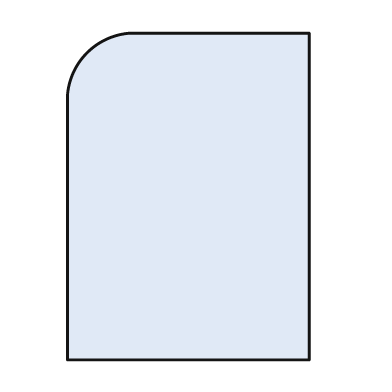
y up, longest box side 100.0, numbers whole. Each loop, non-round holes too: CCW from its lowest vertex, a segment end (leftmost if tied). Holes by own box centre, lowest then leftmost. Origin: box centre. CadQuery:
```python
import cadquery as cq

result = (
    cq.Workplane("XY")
    .moveTo(-37.0, -50.0)
    .lineTo(37.0, -50.0)
    .lineTo(37.0, 50.0)
    .lineTo(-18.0, 50.0)
    .threePointArc((-31.0, 44.0), (-37.0, 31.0))
    .close()
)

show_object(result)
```